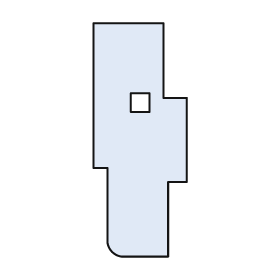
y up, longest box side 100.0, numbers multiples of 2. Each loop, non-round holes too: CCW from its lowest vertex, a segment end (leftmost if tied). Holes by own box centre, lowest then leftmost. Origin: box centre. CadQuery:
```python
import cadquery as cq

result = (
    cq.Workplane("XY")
    .moveTo(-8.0, -50.0)
    .lineTo(12.0, -50.0)
    .lineTo(12.0, -18.0)
    .lineTo(20.0, -18.0)
    .lineTo(20.0, 18.0)
    .lineTo(10.0, 18.0)
    .lineTo(10.0, 50.0)
    .lineTo(-20.0, 50.0)
    .lineTo(-20.0, -12.0)
    .lineTo(-14.0, -12.0)
    .lineTo(-14.0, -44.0)
    .threePointArc((-12.0, -48.0), (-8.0, -50.0))
    .close()
    .moveTo(-4.0, 12.0)
    .lineTo(4.0, 12.0)
    .lineTo(4.0, 20.0)
    .lineTo(-4.0, 20.0)
    .close()
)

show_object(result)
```